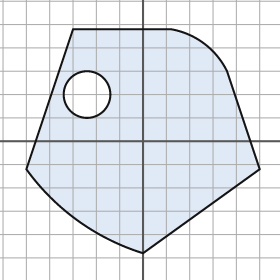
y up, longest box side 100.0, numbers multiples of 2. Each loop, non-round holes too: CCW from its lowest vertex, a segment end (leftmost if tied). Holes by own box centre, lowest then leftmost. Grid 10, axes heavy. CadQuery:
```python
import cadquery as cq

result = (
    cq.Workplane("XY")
    .moveTo(0.0, -48.0)
    .lineTo(50.0, -12.0)
    .lineTo(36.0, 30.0)
    .threePointArc((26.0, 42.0), (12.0, 48.0))
    .lineTo(-30.0, 48.0)
    .lineTo(-50.0, -12.0)
    .threePointArc((-28.0, -34.0), (0.0, -48.0))
    .close()
    .moveTo(-24.0, 20.0)
    .circle(10.0)
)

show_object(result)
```